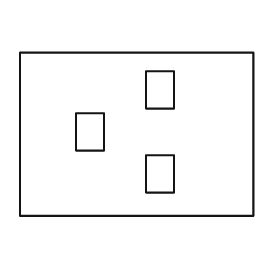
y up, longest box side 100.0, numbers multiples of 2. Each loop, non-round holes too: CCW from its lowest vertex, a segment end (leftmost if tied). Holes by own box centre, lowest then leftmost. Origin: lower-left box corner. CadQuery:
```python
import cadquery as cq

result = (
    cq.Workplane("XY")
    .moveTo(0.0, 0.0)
    .lineTo(100.0, 0.0)
    .lineTo(100.0, 70.0)
    .lineTo(0.0, 70.0)
    .close()
    .moveTo(54.0, 10.0)
    .lineTo(66.0, 10.0)
    .lineTo(66.0, 26.0)
    .lineTo(54.0, 26.0)
    .close()
    .moveTo(24.0, 28.0)
    .lineTo(36.0, 28.0)
    .lineTo(36.0, 44.0)
    .lineTo(24.0, 44.0)
    .close()
    .moveTo(54.0, 46.0)
    .lineTo(66.0, 46.0)
    .lineTo(66.0, 62.0)
    .lineTo(54.0, 62.0)
    .close()
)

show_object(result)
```